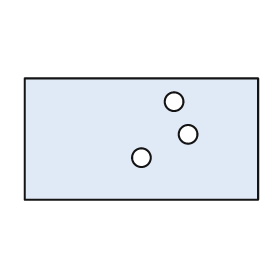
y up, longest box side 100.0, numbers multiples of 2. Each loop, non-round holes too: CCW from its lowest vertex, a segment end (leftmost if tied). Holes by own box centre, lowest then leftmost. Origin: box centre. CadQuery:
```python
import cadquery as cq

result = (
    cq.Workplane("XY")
    .moveTo(-50.0, -26.0)
    .lineTo(50.0, -26.0)
    .lineTo(50.0, 26.0)
    .lineTo(-50.0, 26.0)
    .close()
    .moveTo(0.0, -8.0)
    .circle(4.0)
    .moveTo(20.0, 2.0)
    .circle(4.0)
    .moveTo(14.0, 16.0)
    .circle(4.0)
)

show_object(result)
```